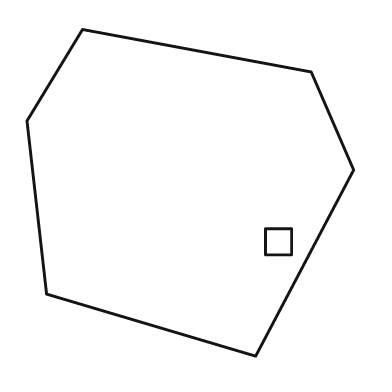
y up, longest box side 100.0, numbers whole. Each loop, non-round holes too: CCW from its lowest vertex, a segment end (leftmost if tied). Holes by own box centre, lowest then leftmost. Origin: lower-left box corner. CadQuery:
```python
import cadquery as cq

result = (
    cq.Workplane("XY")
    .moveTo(70.0, 0.0)
    .lineTo(100.0, 57.0)
    .lineTo(87.0, 87.0)
    .lineTo(17.0, 100.0)
    .lineTo(0.0, 72.0)
    .lineTo(6.0, 19.0)
    .close()
    .moveTo(73.0, 31.0)
    .lineTo(81.0, 31.0)
    .lineTo(81.0, 39.0)
    .lineTo(73.0, 39.0)
    .close()
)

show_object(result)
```